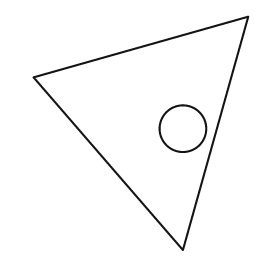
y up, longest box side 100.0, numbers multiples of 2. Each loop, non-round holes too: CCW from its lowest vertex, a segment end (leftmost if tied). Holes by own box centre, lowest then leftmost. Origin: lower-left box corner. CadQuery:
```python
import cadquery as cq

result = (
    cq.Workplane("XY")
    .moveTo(64.0, 0.0)
    .lineTo(92.0, 100.0)
    .lineTo(0.0, 74.0)
    .close()
    .moveTo(64.0, 52.0)
    .circle(10.0)
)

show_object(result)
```